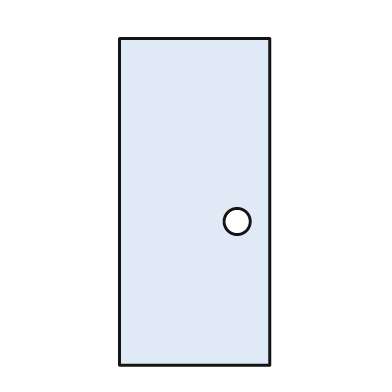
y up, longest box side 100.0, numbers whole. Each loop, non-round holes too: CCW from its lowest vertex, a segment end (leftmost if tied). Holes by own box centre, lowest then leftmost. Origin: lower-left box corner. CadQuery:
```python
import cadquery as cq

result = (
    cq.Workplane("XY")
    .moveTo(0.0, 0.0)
    .lineTo(46.0, 0.0)
    .lineTo(46.0, 100.0)
    .lineTo(0.0, 100.0)
    .close()
    .moveTo(36.0, 44.0)
    .circle(4.0)
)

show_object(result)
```